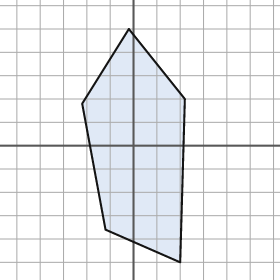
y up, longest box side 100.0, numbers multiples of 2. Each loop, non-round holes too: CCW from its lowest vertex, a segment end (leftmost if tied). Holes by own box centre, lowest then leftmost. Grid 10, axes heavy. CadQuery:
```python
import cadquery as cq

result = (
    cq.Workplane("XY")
    .moveTo(20.0, -50.0)
    .lineTo(22.0, 20.0)
    .lineTo(-2.0, 50.0)
    .lineTo(-22.0, 18.0)
    .lineTo(-12.0, -36.0)
    .close()
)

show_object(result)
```